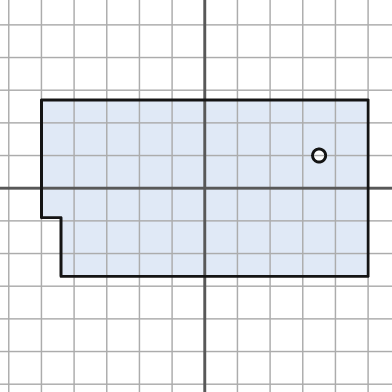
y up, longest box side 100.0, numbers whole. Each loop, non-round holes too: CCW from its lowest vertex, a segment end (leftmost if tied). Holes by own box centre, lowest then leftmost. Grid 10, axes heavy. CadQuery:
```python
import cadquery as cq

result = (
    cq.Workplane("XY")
    .moveTo(-44.0, -27.0)
    .lineTo(50.0, -27.0)
    .lineTo(50.0, 27.0)
    .lineTo(-50.0, 27.0)
    .lineTo(-50.0, -9.0)
    .lineTo(-44.0, -9.0)
    .close()
    .moveTo(35.0, 10.0)
    .circle(2.0)
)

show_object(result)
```